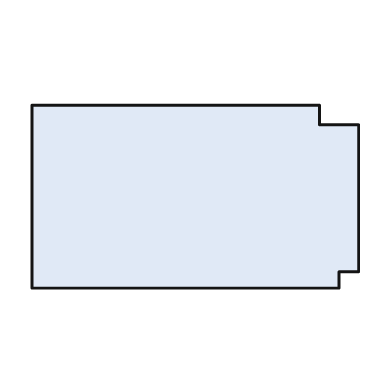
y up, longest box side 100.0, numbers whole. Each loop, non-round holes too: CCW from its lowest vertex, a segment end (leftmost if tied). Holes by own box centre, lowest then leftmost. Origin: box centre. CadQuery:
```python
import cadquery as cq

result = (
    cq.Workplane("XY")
    .moveTo(-50.0, -28.0)
    .lineTo(44.0, -28.0)
    .lineTo(44.0, -23.0)
    .lineTo(50.0, -23.0)
    .lineTo(50.0, 22.0)
    .lineTo(38.0, 22.0)
    .lineTo(38.0, 28.0)
    .lineTo(-50.0, 28.0)
    .close()
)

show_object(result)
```